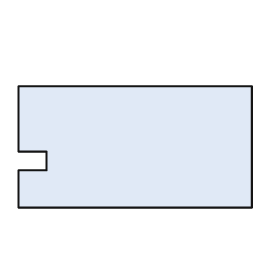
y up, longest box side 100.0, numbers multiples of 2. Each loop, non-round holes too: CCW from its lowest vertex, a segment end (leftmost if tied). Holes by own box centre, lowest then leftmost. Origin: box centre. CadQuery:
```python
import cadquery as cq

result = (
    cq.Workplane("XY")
    .moveTo(-50.0, -26.0)
    .lineTo(50.0, -26.0)
    .lineTo(50.0, 26.0)
    .lineTo(-50.0, 26.0)
    .lineTo(-50.0, -2.0)
    .lineTo(-38.0, -2.0)
    .lineTo(-38.0, -10.0)
    .lineTo(-50.0, -10.0)
    .close()
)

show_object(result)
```